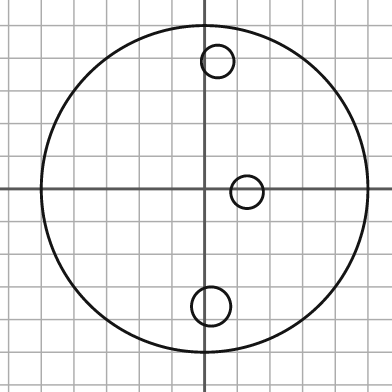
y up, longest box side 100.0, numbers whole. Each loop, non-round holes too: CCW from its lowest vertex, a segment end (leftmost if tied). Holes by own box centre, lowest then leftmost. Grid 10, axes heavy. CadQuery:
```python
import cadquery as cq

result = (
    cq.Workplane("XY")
    .moveTo(0.0, 0.0)
    .circle(50.0)
    .moveTo(2.0, -36.0)
    .circle(6.0)
    .moveTo(13.0, -1.0)
    .circle(5.0)
    .moveTo(4.0, 39.0)
    .circle(5.0)
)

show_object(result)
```